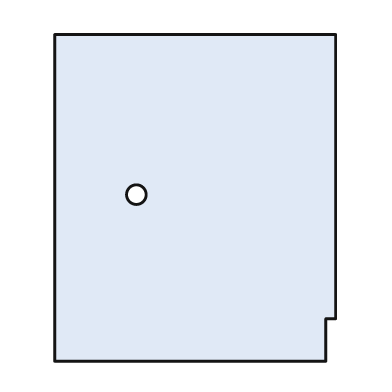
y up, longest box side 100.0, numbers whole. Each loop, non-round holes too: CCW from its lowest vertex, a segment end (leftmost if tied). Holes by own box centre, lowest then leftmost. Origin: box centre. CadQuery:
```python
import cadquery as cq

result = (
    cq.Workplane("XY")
    .moveTo(-43.0, -50.0)
    .lineTo(40.0, -50.0)
    .lineTo(40.0, -37.0)
    .lineTo(43.0, -37.0)
    .lineTo(43.0, 50.0)
    .lineTo(-43.0, 50.0)
    .close()
    .moveTo(-18.0, 1.0)
    .circle(3.0)
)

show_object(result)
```